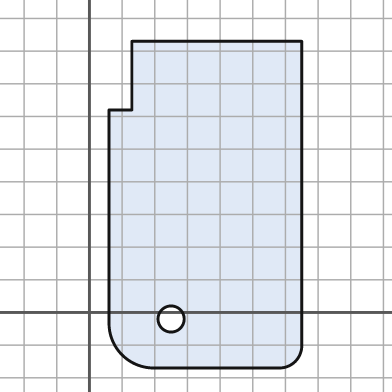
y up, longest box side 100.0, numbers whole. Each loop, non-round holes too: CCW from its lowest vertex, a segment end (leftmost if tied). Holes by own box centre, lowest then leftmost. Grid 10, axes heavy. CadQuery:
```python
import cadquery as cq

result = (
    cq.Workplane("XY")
    .moveTo(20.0, -17.0)
    .lineTo(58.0, -17.0)
    .threePointArc((63.0, -15.0), (65.0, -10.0))
    .lineTo(65.0, 83.0)
    .lineTo(13.0, 83.0)
    .lineTo(13.0, 62.0)
    .lineTo(6.0, 62.0)
    .lineTo(6.0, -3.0)
    .threePointArc((10.0, -13.0), (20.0, -17.0))
    .close()
    .moveTo(25.0, -2.0)
    .circle(4.0)
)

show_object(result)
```